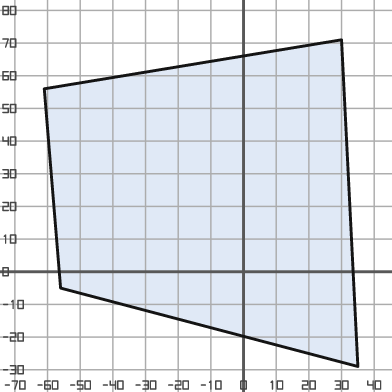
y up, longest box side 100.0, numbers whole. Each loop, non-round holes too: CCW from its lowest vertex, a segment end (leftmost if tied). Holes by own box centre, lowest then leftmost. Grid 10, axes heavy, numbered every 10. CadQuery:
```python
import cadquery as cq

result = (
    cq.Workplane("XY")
    .moveTo(35.0, -29.0)
    .lineTo(30.0, 71.0)
    .lineTo(-61.0, 56.0)
    .lineTo(-56.0, -5.0)
    .close()
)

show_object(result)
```